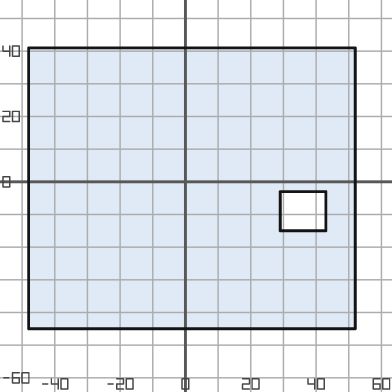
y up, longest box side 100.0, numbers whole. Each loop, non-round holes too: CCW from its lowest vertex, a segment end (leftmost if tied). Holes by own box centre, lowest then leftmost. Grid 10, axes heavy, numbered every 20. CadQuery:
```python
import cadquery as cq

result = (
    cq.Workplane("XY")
    .moveTo(-48.0, -45.0)
    .lineTo(52.0, -45.0)
    .lineTo(52.0, 41.0)
    .lineTo(-48.0, 41.0)
    .close()
    .moveTo(29.0, -15.0)
    .lineTo(43.0, -15.0)
    .lineTo(43.0, -3.0)
    .lineTo(29.0, -3.0)
    .close()
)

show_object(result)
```